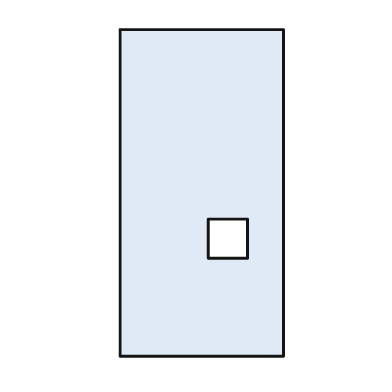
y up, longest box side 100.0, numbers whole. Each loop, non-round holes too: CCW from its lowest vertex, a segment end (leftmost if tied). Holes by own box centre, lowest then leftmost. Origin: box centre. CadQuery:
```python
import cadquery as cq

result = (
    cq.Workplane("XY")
    .moveTo(-25.0, -50.0)
    .lineTo(25.0, -50.0)
    .lineTo(25.0, 50.0)
    .lineTo(-25.0, 50.0)
    .close()
    .moveTo(2.0, -20.0)
    .lineTo(14.0, -20.0)
    .lineTo(14.0, -8.0)
    .lineTo(2.0, -8.0)
    .close()
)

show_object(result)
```